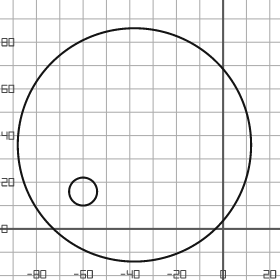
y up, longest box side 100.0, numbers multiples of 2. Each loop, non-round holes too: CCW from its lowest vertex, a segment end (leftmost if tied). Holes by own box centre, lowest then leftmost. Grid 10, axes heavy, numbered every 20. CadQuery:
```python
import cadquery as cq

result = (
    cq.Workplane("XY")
    .moveTo(-38.0, 36.0)
    .circle(50.0)
    .moveTo(-60.0, 16.0)
    .circle(6.0)
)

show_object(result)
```